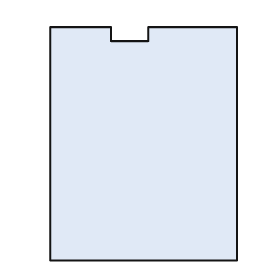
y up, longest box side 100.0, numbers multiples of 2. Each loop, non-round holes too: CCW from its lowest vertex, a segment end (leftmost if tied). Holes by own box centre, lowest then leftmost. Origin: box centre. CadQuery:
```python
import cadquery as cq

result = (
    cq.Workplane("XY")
    .moveTo(-40.0, -50.0)
    .lineTo(40.0, -50.0)
    .lineTo(40.0, 50.0)
    .lineTo(2.0, 50.0)
    .lineTo(2.0, 44.0)
    .lineTo(-14.0, 44.0)
    .lineTo(-14.0, 50.0)
    .lineTo(-40.0, 50.0)
    .close()
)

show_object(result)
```